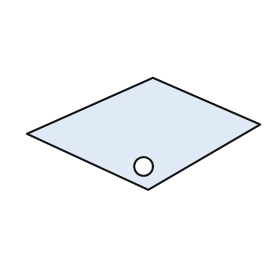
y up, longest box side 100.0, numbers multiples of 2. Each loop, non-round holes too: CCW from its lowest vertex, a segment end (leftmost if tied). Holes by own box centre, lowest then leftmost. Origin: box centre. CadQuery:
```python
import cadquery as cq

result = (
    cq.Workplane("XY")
    .moveTo(2.0, -24.0)
    .lineTo(50.0, 4.0)
    .lineTo(4.0, 24.0)
    .lineTo(-50.0, 0.0)
    .close()
    .moveTo(0.0, -14.0)
    .circle(4.0)
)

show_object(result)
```